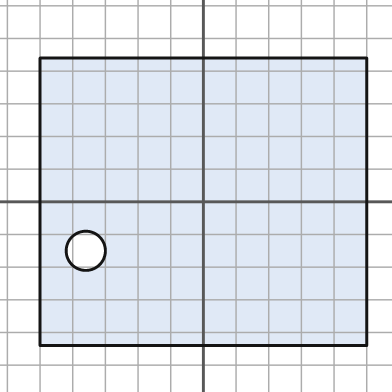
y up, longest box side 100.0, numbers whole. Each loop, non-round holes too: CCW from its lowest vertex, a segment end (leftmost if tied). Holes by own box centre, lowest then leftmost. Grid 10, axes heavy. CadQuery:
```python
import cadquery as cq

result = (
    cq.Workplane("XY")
    .moveTo(-50.0, -44.0)
    .lineTo(50.0, -44.0)
    .lineTo(50.0, 44.0)
    .lineTo(-50.0, 44.0)
    .close()
    .moveTo(-36.0, -15.0)
    .circle(6.0)
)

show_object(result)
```